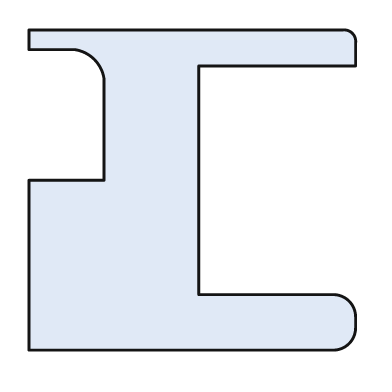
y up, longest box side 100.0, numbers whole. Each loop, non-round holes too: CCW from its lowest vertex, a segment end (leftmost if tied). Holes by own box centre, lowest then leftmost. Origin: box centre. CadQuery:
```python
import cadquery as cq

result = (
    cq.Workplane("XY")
    .moveTo(-50.0, -49.0)
    .lineTo(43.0, -49.0)
    .threePointArc((48.0, -47.0), (50.0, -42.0))
    .lineTo(50.0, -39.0)
    .threePointArc((48.0, -34.0), (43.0, -32.0))
    .lineTo(2.0, -32.0)
    .lineTo(2.0, 38.0)
    .lineTo(50.0, 38.0)
    .lineTo(50.0, 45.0)
    .threePointArc((49.0, 48.0), (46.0, 49.0))
    .lineTo(-50.0, 49.0)
    .lineTo(-50.0, 43.0)
    .lineTo(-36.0, 43.0)
    .threePointArc((-30.0, 40.0), (-27.0, 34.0))
    .lineTo(-27.0, 3.0)
    .lineTo(-50.0, 3.0)
    .close()
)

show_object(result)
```